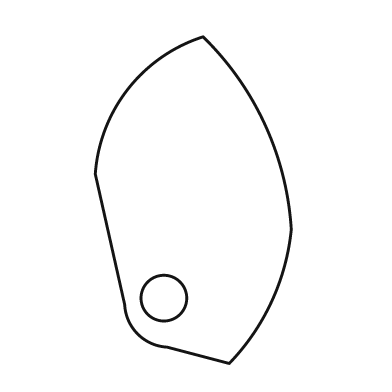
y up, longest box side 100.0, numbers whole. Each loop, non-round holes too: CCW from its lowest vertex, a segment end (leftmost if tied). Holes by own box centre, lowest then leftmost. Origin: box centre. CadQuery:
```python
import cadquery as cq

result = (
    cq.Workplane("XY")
    .moveTo(11.0, -50.0)
    .threePointArc((24.0, -31.0), (30.0, -9.0))
    .threePointArc((22.0, 23.0), (3.0, 50.0))
    .threePointArc((-20.0, 34.0), (-30.0, 8.0))
    .lineTo(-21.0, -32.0)
    .threePointArc((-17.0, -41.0), (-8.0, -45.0))
    .close()
    .moveTo(-9.0, -30.0)
    .circle(7.0)
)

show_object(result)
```